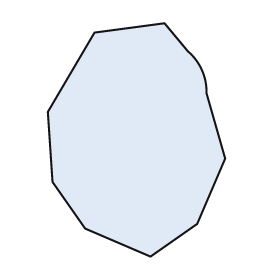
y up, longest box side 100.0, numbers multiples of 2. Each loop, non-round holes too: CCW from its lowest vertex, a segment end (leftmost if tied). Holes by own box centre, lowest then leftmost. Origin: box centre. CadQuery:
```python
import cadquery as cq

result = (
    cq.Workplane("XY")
    .moveTo(6.0, -50.0)
    .lineTo(26.0, -36.0)
    .lineTo(38.0, -8.0)
    .lineTo(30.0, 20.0)
    .threePointArc((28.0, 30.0), (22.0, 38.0))
    .lineTo(12.0, 50.0)
    .lineTo(-18.0, 46.0)
    .lineTo(-38.0, 12.0)
    .lineTo(-36.0, -18.0)
    .lineTo(-22.0, -38.0)
    .close()
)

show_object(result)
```